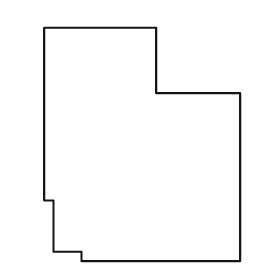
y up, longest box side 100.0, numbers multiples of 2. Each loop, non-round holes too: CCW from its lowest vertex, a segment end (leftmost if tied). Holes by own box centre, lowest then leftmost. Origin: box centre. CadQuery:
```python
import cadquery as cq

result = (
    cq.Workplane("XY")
    .moveTo(-26.0, -50.0)
    .lineTo(42.0, -50.0)
    .lineTo(42.0, 22.0)
    .lineTo(6.0, 22.0)
    .lineTo(6.0, 50.0)
    .lineTo(-42.0, 50.0)
    .lineTo(-42.0, -24.0)
    .lineTo(-38.0, -24.0)
    .lineTo(-38.0, -46.0)
    .lineTo(-26.0, -46.0)
    .close()
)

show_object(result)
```